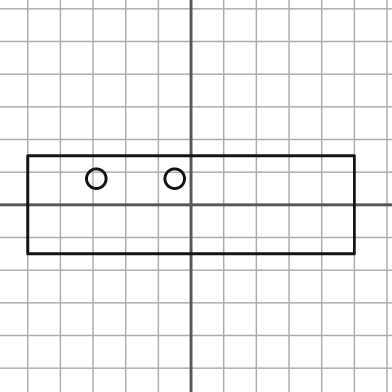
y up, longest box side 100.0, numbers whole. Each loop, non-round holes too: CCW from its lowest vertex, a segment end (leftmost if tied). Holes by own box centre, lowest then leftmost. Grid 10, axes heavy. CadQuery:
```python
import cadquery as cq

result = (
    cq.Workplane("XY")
    .moveTo(-50.0, -15.0)
    .lineTo(50.0, -15.0)
    .lineTo(50.0, 15.0)
    .lineTo(-50.0, 15.0)
    .close()
    .moveTo(-29.0, 8.0)
    .circle(3.0)
    .moveTo(-5.0, 8.0)
    .circle(3.0)
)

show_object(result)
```